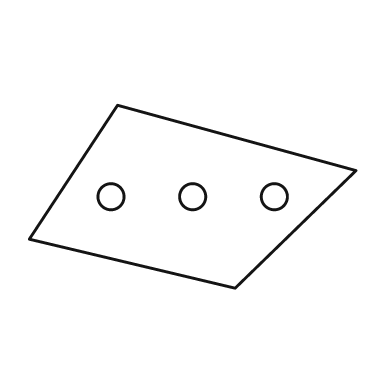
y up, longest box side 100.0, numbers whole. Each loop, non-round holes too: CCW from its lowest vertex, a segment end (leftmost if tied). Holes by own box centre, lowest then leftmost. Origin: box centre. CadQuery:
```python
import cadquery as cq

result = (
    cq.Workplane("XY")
    .moveTo(13.0, -28.0)
    .lineTo(50.0, 8.0)
    .lineTo(-23.0, 28.0)
    .lineTo(-50.0, -13.0)
    .close()
    .moveTo(-25.0, 0.0)
    .circle(4.0)
    .moveTo(0.0, 0.0)
    .circle(4.0)
    .moveTo(25.0, 0.0)
    .circle(4.0)
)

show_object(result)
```